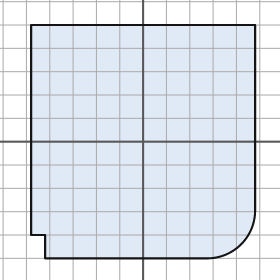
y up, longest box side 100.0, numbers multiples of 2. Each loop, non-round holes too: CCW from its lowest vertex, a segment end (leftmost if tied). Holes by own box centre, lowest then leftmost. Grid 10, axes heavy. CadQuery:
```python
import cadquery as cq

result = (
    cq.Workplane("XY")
    .moveTo(-42.0, -50.0)
    .lineTo(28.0, -50.0)
    .threePointArc((42.0, -44.0), (48.0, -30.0))
    .lineTo(48.0, 50.0)
    .lineTo(-48.0, 50.0)
    .lineTo(-48.0, -40.0)
    .lineTo(-42.0, -40.0)
    .close()
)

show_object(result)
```